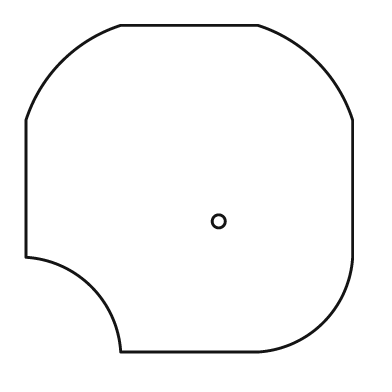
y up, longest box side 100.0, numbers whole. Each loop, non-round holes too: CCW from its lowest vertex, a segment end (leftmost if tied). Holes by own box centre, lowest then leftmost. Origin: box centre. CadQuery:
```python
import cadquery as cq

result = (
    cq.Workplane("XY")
    .moveTo(-21.0, -50.0)
    .lineTo(21.0, -50.0)
    .threePointArc((41.0, -41.0), (50.0, -21.0))
    .lineTo(50.0, 21.0)
    .threePointArc((39.0, 39.0), (21.0, 50.0))
    .lineTo(-21.0, 50.0)
    .threePointArc((-39.0, 39.0), (-50.0, 21.0))
    .lineTo(-50.0, -21.0)
    .threePointArc((-30.0, -30.0), (-21.0, -50.0))
    .close()
    .moveTo(9.0, -10.0)
    .circle(2.0)
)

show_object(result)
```